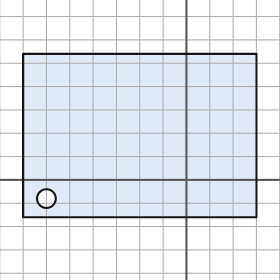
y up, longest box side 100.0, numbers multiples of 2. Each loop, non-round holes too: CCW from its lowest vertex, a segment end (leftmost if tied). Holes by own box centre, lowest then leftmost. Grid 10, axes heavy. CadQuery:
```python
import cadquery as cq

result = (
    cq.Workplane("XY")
    .moveTo(-70.0, -16.0)
    .lineTo(30.0, -16.0)
    .lineTo(30.0, 54.0)
    .lineTo(-70.0, 54.0)
    .close()
    .moveTo(-60.0, -8.0)
    .circle(4.0)
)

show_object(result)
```